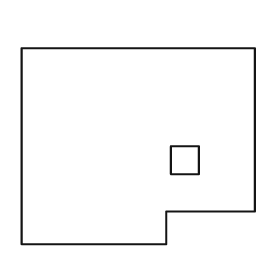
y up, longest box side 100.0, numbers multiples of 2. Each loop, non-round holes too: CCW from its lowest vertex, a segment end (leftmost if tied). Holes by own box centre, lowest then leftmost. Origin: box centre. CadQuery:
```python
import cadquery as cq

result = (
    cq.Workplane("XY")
    .moveTo(-50.0, -42.0)
    .lineTo(12.0, -42.0)
    .lineTo(12.0, -28.0)
    .lineTo(50.0, -28.0)
    .lineTo(50.0, 42.0)
    .lineTo(-50.0, 42.0)
    .close()
    .moveTo(14.0, -12.0)
    .lineTo(26.0, -12.0)
    .lineTo(26.0, 0.0)
    .lineTo(14.0, 0.0)
    .close()
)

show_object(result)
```